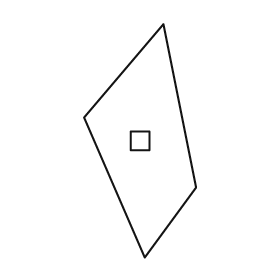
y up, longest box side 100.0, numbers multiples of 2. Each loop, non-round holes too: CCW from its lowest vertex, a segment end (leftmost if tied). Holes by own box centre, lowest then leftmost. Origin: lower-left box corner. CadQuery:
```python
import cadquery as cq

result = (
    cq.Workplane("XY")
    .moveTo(26.0, 0.0)
    .lineTo(48.0, 30.0)
    .lineTo(34.0, 100.0)
    .lineTo(0.0, 60.0)
    .close()
    .moveTo(20.0, 46.0)
    .lineTo(28.0, 46.0)
    .lineTo(28.0, 54.0)
    .lineTo(20.0, 54.0)
    .close()
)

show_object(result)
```